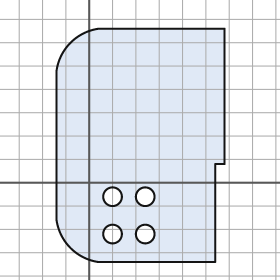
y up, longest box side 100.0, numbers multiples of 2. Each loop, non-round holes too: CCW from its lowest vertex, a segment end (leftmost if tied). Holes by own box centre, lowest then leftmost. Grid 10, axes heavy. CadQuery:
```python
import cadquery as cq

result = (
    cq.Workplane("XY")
    .moveTo(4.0, -34.0)
    .lineTo(54.0, -34.0)
    .lineTo(54.0, 8.0)
    .lineTo(58.0, 8.0)
    .lineTo(58.0, 66.0)
    .lineTo(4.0, 66.0)
    .threePointArc((-8.0, 60.0), (-14.0, 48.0))
    .lineTo(-14.0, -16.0)
    .threePointArc((-8.0, -28.0), (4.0, -34.0))
    .close()
    .moveTo(10.0, -22.0)
    .circle(4.0)
    .moveTo(24.0, -22.0)
    .circle(4.0)
    .moveTo(10.0, -6.0)
    .circle(4.0)
    .moveTo(24.0, -6.0)
    .circle(4.0)
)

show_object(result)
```